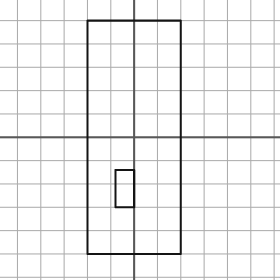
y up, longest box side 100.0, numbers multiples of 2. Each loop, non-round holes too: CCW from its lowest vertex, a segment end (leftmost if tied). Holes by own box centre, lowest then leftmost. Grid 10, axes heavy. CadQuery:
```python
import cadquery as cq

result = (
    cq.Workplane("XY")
    .moveTo(-20.0, -50.0)
    .lineTo(20.0, -50.0)
    .lineTo(20.0, 50.0)
    .lineTo(-20.0, 50.0)
    .close()
    .moveTo(-8.0, -30.0)
    .lineTo(0.0, -30.0)
    .lineTo(0.0, -14.0)
    .lineTo(-8.0, -14.0)
    .close()
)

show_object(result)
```